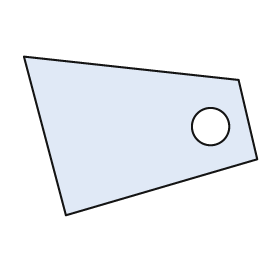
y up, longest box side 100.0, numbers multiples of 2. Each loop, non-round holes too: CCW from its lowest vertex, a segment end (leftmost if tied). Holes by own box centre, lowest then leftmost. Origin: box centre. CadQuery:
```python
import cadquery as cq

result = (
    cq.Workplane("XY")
    .moveTo(-32.0, -34.0)
    .lineTo(50.0, -10.0)
    .lineTo(42.0, 24.0)
    .lineTo(-50.0, 34.0)
    .close()
    .moveTo(30.0, 4.0)
    .circle(8.0)
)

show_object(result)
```